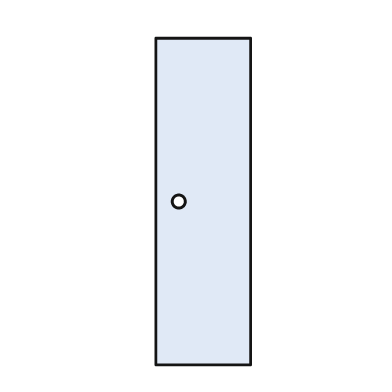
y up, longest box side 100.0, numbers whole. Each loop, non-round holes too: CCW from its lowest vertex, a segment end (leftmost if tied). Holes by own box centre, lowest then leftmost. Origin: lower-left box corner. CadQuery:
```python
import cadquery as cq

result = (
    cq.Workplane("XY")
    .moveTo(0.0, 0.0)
    .lineTo(29.0, 0.0)
    .lineTo(29.0, 100.0)
    .lineTo(0.0, 100.0)
    .close()
    .moveTo(7.0, 50.0)
    .circle(2.0)
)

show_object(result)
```